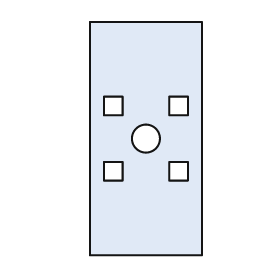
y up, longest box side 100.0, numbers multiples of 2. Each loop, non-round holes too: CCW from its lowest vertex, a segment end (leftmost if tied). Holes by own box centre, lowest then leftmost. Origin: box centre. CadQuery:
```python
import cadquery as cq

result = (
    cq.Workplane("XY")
    .moveTo(-24.0, -50.0)
    .lineTo(24.0, -50.0)
    .lineTo(24.0, 50.0)
    .lineTo(-24.0, 50.0)
    .close()
    .moveTo(-18.0, -18.0)
    .lineTo(-10.0, -18.0)
    .lineTo(-10.0, -10.0)
    .lineTo(-18.0, -10.0)
    .close()
    .moveTo(10.0, -18.0)
    .lineTo(18.0, -18.0)
    .lineTo(18.0, -10.0)
    .lineTo(10.0, -10.0)
    .close()
    .moveTo(0.0, 0.0)
    .circle(6.0)
    .moveTo(-18.0, 10.0)
    .lineTo(-10.0, 10.0)
    .lineTo(-10.0, 18.0)
    .lineTo(-18.0, 18.0)
    .close()
    .moveTo(10.0, 10.0)
    .lineTo(18.0, 10.0)
    .lineTo(18.0, 18.0)
    .lineTo(10.0, 18.0)
    .close()
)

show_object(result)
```